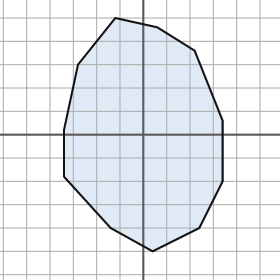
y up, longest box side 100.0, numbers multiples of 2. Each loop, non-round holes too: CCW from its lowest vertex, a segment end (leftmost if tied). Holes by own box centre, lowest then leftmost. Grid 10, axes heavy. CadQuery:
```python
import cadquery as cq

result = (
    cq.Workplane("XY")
    .moveTo(4.0, -50.0)
    .lineTo(24.0, -40.0)
    .lineTo(34.0, -20.0)
    .lineTo(34.0, 6.0)
    .lineTo(22.0, 36.0)
    .lineTo(6.0, 46.0)
    .lineTo(-12.0, 50.0)
    .lineTo(-28.0, 30.0)
    .lineTo(-34.0, 2.0)
    .lineTo(-34.0, -18.0)
    .lineTo(-14.0, -40.0)
    .close()
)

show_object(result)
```